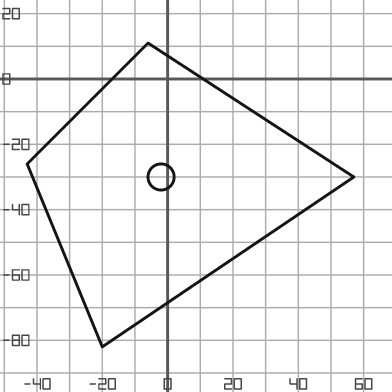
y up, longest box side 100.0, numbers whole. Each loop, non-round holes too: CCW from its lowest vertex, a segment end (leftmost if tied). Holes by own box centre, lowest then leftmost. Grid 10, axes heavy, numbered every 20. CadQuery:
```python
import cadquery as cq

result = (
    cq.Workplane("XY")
    .moveTo(-20.0, -82.0)
    .lineTo(57.0, -30.0)
    .lineTo(-6.0, 11.0)
    .lineTo(-43.0, -26.0)
    .close()
    .moveTo(-2.0, -30.0)
    .circle(4.0)
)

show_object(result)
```